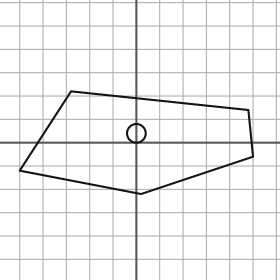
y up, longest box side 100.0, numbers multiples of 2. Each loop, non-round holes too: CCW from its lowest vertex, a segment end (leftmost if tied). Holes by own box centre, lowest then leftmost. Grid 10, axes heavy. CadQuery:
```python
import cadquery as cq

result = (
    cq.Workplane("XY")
    .moveTo(2.0, -22.0)
    .lineTo(50.0, -6.0)
    .lineTo(48.0, 14.0)
    .lineTo(-28.0, 22.0)
    .lineTo(-50.0, -12.0)
    .close()
    .moveTo(0.0, 4.0)
    .circle(4.0)
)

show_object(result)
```